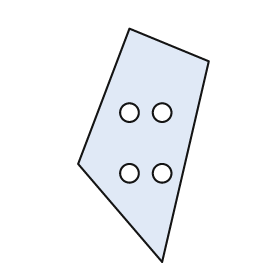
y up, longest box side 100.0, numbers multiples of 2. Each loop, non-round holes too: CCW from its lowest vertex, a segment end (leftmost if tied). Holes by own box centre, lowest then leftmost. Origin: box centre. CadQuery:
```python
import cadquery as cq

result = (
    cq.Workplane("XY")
    .moveTo(8.0, -50.0)
    .lineTo(28.0, 36.0)
    .lineTo(-6.0, 50.0)
    .lineTo(-28.0, -8.0)
    .close()
    .moveTo(-6.0, -12.0)
    .circle(4.0)
    .moveTo(8.0, -12.0)
    .circle(4.0)
    .moveTo(-6.0, 14.0)
    .circle(4.0)
    .moveTo(8.0, 14.0)
    .circle(4.0)
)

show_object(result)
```